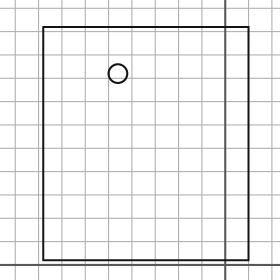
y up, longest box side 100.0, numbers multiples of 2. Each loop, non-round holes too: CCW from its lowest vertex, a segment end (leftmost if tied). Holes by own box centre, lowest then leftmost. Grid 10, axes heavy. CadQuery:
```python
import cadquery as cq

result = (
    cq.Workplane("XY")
    .moveTo(-78.0, 2.0)
    .lineTo(10.0, 2.0)
    .lineTo(10.0, 102.0)
    .lineTo(-78.0, 102.0)
    .close()
    .moveTo(-46.0, 82.0)
    .circle(4.0)
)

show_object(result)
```